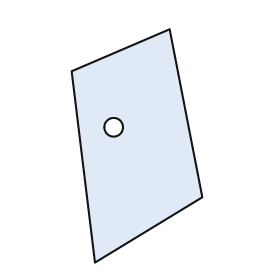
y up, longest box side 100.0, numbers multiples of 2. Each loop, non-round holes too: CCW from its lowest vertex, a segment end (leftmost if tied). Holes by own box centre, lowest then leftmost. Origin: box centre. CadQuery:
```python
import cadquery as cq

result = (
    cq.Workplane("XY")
    .moveTo(-18.0, -50.0)
    .lineTo(28.0, -22.0)
    .lineTo(14.0, 50.0)
    .lineTo(-28.0, 32.0)
    .close()
    .moveTo(-10.0, 8.0)
    .circle(4.0)
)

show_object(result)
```